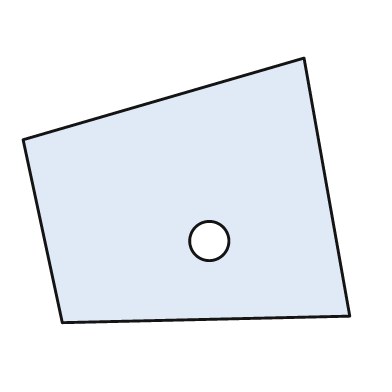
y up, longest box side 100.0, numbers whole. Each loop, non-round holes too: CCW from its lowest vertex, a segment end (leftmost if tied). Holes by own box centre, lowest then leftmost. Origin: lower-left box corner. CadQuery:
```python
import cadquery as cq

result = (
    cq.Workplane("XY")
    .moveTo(12.0, 0.0)
    .lineTo(100.0, 2.0)
    .lineTo(86.0, 81.0)
    .lineTo(0.0, 56.0)
    .close()
    .moveTo(57.0, 25.0)
    .circle(6.0)
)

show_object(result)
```